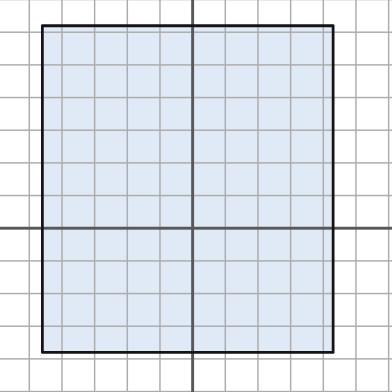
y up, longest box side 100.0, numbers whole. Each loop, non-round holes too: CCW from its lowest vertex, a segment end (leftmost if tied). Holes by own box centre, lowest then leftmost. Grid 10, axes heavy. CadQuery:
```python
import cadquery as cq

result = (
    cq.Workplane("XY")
    .moveTo(-46.0, -38.0)
    .lineTo(43.0, -38.0)
    .lineTo(43.0, 62.0)
    .lineTo(-46.0, 62.0)
    .close()
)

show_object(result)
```